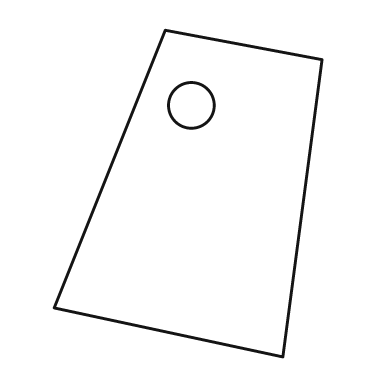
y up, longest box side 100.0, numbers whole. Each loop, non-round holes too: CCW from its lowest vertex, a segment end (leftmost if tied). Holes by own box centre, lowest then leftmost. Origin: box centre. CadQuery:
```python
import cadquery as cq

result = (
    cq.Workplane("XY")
    .moveTo(29.0, -50.0)
    .lineTo(41.0, 41.0)
    .lineTo(-7.0, 50.0)
    .lineTo(-41.0, -35.0)
    .close()
    .moveTo(1.0, 27.0)
    .circle(7.0)
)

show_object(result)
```